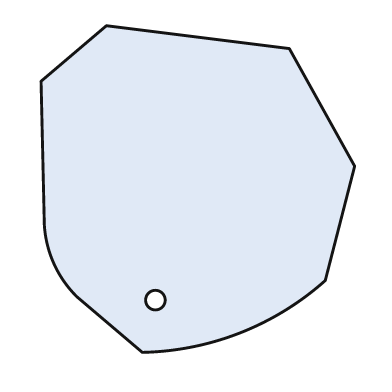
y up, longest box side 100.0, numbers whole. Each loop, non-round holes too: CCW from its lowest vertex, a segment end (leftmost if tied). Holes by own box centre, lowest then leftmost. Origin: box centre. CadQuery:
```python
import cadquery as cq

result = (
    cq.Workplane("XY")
    .moveTo(-17.0, -50.0)
    .threePointArc((13.0, -44.0), (39.0, -28.0))
    .lineTo(48.0, 7.0)
    .lineTo(28.0, 43.0)
    .lineTo(-28.0, 50.0)
    .lineTo(-48.0, 33.0)
    .lineTo(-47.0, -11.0)
    .threePointArc((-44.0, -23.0), (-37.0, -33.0))
    .close()
    .moveTo(-13.0, -34.0)
    .circle(3.0)
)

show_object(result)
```